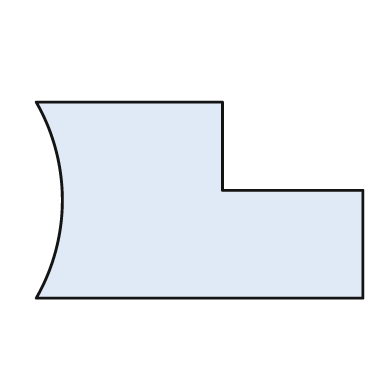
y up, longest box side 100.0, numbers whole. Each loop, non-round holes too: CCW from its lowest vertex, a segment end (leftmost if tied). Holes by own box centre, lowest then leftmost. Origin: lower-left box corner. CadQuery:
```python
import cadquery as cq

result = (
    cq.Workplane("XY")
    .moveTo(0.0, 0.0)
    .lineTo(100.0, 0.0)
    .lineTo(100.0, 33.0)
    .lineTo(57.0, 33.0)
    .lineTo(57.0, 60.0)
    .lineTo(0.0, 60.0)
    .threePointArc((8.0, 30.0), (0.0, 0.0))
    .close()
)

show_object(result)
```